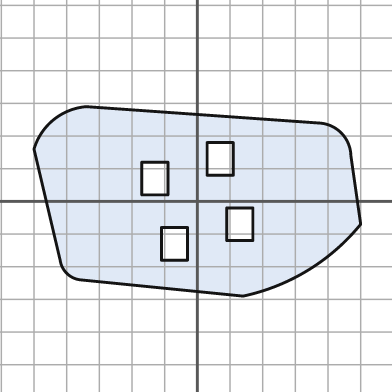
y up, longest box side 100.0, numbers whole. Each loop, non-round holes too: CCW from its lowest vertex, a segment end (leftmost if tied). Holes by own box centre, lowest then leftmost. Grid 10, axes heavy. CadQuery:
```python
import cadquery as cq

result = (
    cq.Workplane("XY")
    .moveTo(14.0, -29.0)
    .threePointArc((34.0, -21.0), (50.0, -7.0))
    .lineTo(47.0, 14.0)
    .threePointArc((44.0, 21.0), (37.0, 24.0))
    .lineTo(-34.0, 29.0)
    .threePointArc((-44.0, 25.0), (-50.0, 16.0))
    .lineTo(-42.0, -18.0)
    .threePointArc((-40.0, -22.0), (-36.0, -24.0))
    .close()
    .moveTo(-11.0, -18.0)
    .lineTo(-3.0, -18.0)
    .lineTo(-3.0, -8.0)
    .lineTo(-11.0, -8.0)
    .close()
    .moveTo(9.0, -12.0)
    .lineTo(17.0, -12.0)
    .lineTo(17.0, -2.0)
    .lineTo(9.0, -2.0)
    .close()
    .moveTo(-17.0, 2.0)
    .lineTo(-9.0, 2.0)
    .lineTo(-9.0, 12.0)
    .lineTo(-17.0, 12.0)
    .close()
    .moveTo(3.0, 8.0)
    .lineTo(11.0, 8.0)
    .lineTo(11.0, 18.0)
    .lineTo(3.0, 18.0)
    .close()
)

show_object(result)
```